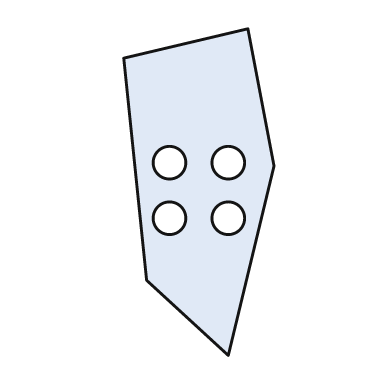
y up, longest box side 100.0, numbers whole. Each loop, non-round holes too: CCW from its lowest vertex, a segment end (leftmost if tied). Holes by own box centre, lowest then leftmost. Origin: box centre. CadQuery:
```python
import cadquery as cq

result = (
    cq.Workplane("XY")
    .moveTo(9.0, -50.0)
    .lineTo(23.0, 8.0)
    .lineTo(15.0, 50.0)
    .lineTo(-23.0, 41.0)
    .lineTo(-16.0, -27.0)
    .close()
    .moveTo(-9.0, -8.0)
    .circle(5.0)
    .moveTo(9.0, -8.0)
    .circle(5.0)
    .moveTo(-9.0, 9.0)
    .circle(5.0)
    .moveTo(9.0, 9.0)
    .circle(5.0)
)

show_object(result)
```